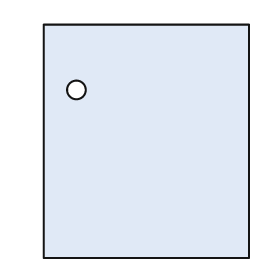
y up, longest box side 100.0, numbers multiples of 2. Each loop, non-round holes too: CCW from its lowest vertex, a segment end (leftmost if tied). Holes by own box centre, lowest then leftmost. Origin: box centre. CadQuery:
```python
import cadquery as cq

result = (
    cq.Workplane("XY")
    .moveTo(-44.0, -50.0)
    .lineTo(44.0, -50.0)
    .lineTo(44.0, 50.0)
    .lineTo(-44.0, 50.0)
    .close()
    .moveTo(-30.0, 22.0)
    .circle(4.0)
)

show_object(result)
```